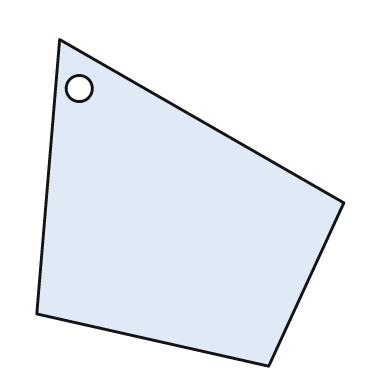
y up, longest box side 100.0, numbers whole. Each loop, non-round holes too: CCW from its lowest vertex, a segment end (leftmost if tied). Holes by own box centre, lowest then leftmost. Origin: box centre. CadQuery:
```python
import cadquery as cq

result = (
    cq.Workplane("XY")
    .moveTo(24.0, -50.0)
    .lineTo(47.0, 0.0)
    .lineTo(-40.0, 50.0)
    .lineTo(-47.0, -34.0)
    .close()
    .moveTo(-34.0, 35.0)
    .circle(4.0)
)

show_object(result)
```